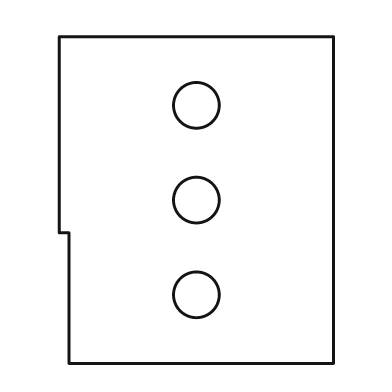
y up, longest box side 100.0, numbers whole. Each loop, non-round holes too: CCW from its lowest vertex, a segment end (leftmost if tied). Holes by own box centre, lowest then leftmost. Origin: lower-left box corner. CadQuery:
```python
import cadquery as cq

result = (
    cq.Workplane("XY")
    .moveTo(3.0, 0.0)
    .lineTo(84.0, 0.0)
    .lineTo(84.0, 100.0)
    .lineTo(0.0, 100.0)
    .lineTo(0.0, 40.0)
    .lineTo(3.0, 40.0)
    .close()
    .moveTo(42.0, 21.0)
    .circle(7.0)
    .moveTo(42.0, 50.0)
    .circle(7.0)
    .moveTo(42.0, 79.0)
    .circle(7.0)
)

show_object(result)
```